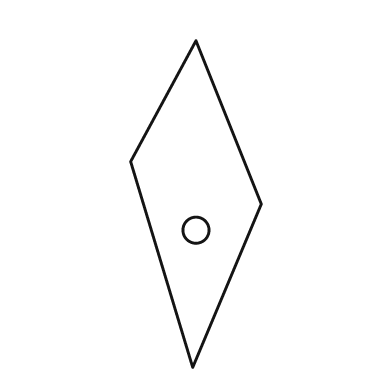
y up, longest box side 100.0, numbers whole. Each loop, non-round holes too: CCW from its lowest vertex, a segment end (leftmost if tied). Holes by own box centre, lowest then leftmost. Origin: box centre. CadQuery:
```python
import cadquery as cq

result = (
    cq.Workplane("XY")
    .moveTo(-1.0, -50.0)
    .lineTo(20.0, 0.0)
    .lineTo(0.0, 50.0)
    .lineTo(-20.0, 13.0)
    .close()
    .moveTo(0.0, -8.0)
    .circle(4.0)
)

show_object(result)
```